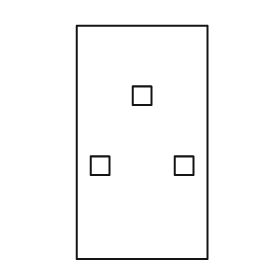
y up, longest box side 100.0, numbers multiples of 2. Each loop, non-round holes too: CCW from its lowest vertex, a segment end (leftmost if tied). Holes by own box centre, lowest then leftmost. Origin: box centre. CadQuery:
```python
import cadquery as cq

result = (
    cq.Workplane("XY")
    .moveTo(-28.0, -50.0)
    .lineTo(28.0, -50.0)
    .lineTo(28.0, 50.0)
    .lineTo(-28.0, 50.0)
    .close()
    .moveTo(-22.0, -14.0)
    .lineTo(-14.0, -14.0)
    .lineTo(-14.0, -6.0)
    .lineTo(-22.0, -6.0)
    .close()
    .moveTo(14.0, -14.0)
    .lineTo(22.0, -14.0)
    .lineTo(22.0, -6.0)
    .lineTo(14.0, -6.0)
    .close()
    .moveTo(-4.0, 16.0)
    .lineTo(4.0, 16.0)
    .lineTo(4.0, 24.0)
    .lineTo(-4.0, 24.0)
    .close()
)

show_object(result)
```